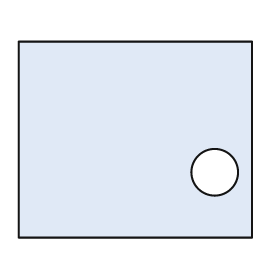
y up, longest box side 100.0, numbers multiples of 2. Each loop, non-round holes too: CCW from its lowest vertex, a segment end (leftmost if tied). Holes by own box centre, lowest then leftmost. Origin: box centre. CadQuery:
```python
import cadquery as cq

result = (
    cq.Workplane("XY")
    .moveTo(-50.0, -42.0)
    .lineTo(50.0, -42.0)
    .lineTo(50.0, 42.0)
    .lineTo(-50.0, 42.0)
    .close()
    .moveTo(34.0, -14.0)
    .circle(10.0)
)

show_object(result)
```